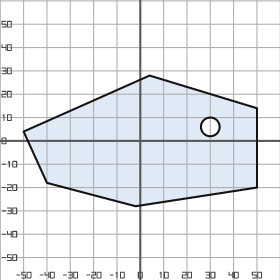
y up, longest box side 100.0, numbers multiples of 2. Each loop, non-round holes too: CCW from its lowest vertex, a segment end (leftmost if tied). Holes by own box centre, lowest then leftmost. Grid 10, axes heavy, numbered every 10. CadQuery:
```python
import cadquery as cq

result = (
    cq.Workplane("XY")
    .moveTo(-2.0, -28.0)
    .lineTo(50.0, -20.0)
    .lineTo(50.0, 14.0)
    .lineTo(4.0, 28.0)
    .lineTo(-50.0, 4.0)
    .lineTo(-40.0, -18.0)
    .close()
    .moveTo(30.0, 6.0)
    .circle(4.0)
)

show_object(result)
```